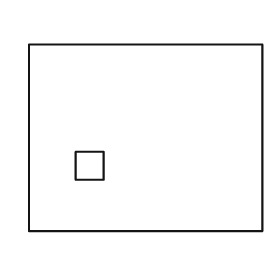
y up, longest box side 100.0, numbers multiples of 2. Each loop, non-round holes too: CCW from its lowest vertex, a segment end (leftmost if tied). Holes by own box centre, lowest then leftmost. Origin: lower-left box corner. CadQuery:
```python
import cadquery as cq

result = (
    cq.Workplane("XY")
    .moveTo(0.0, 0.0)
    .lineTo(100.0, 0.0)
    .lineTo(100.0, 80.0)
    .lineTo(0.0, 80.0)
    .close()
    .moveTo(20.0, 22.0)
    .lineTo(32.0, 22.0)
    .lineTo(32.0, 34.0)
    .lineTo(20.0, 34.0)
    .close()
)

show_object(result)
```